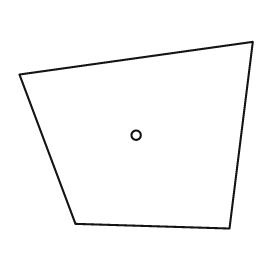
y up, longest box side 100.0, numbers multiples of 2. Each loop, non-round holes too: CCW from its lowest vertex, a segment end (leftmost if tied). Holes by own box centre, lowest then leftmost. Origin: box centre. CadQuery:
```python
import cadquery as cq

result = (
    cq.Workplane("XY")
    .moveTo(40.0, -40.0)
    .lineTo(50.0, 40.0)
    .lineTo(-50.0, 26.0)
    .lineTo(-26.0, -38.0)
    .close()
    .moveTo(0.0, 0.0)
    .circle(2.0)
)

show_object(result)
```